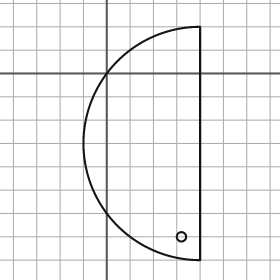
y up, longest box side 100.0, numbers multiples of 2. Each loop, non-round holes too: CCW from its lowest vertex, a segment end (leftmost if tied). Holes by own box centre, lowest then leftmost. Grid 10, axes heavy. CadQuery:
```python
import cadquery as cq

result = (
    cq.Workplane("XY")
    .moveTo(40.0, -80.0)
    .lineTo(40.0, 20.0)
    .threePointArc((-10.0, -30.0), (40.0, -80.0))
    .close()
    .moveTo(32.0, -70.0)
    .circle(2.0)
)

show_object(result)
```